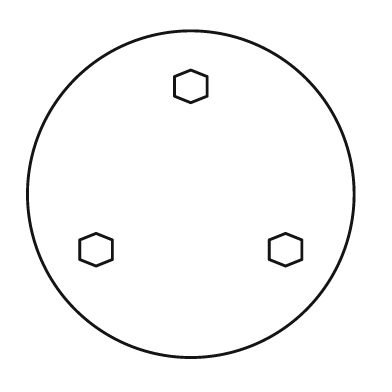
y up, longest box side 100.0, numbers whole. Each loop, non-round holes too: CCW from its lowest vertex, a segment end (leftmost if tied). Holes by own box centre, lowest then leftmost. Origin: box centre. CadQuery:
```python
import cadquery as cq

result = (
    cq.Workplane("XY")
    .moveTo(0.0, 0.0)
    .circle(50.0)
    .moveTo(-29.0, -22.0)
    .lineTo(-24.0, -20.0)
    .lineTo(-24.0, -14.0)
    .lineTo(-29.0, -12.0)
    .lineTo(-34.0, -14.0)
    .lineTo(-34.0, -20.0)
    .close()
    .moveTo(29.0, -22.0)
    .lineTo(34.0, -20.0)
    .lineTo(34.0, -14.0)
    .lineTo(29.0, -12.0)
    .lineTo(24.0, -14.0)
    .lineTo(24.0, -20.0)
    .close()
    .moveTo(0.0, 28.0)
    .lineTo(5.0, 30.0)
    .lineTo(5.0, 36.0)
    .lineTo(0.0, 38.0)
    .lineTo(-5.0, 36.0)
    .lineTo(-5.0, 30.0)
    .close()
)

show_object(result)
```